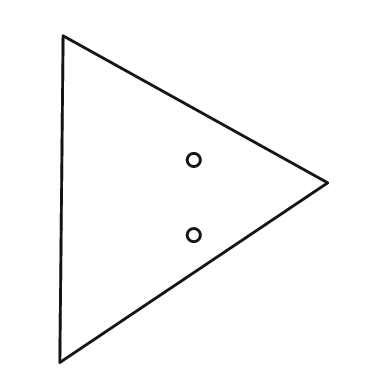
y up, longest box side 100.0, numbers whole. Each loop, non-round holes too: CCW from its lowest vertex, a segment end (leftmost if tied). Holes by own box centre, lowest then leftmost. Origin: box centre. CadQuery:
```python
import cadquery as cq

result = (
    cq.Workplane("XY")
    .moveTo(-41.0, -50.0)
    .lineTo(41.0, 5.0)
    .lineTo(-40.0, 50.0)
    .close()
    .moveTo(0.0, -11.0)
    .circle(2.0)
    .moveTo(0.0, 12.0)
    .circle(2.0)
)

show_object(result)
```